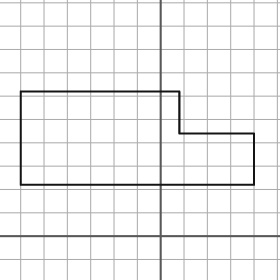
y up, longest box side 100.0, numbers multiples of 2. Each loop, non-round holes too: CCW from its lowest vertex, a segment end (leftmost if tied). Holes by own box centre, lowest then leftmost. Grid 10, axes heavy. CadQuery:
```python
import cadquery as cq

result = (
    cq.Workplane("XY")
    .moveTo(-60.0, 22.0)
    .lineTo(40.0, 22.0)
    .lineTo(40.0, 44.0)
    .lineTo(8.0, 44.0)
    .lineTo(8.0, 62.0)
    .lineTo(-60.0, 62.0)
    .close()
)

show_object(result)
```